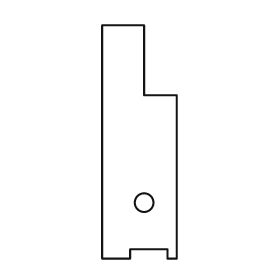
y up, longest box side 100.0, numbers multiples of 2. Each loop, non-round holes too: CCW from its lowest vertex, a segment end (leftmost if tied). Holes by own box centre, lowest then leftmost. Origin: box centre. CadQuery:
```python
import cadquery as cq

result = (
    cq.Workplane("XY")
    .moveTo(-16.0, -50.0)
    .lineTo(-4.0, -50.0)
    .lineTo(-4.0, -46.0)
    .lineTo(12.0, -46.0)
    .lineTo(12.0, -50.0)
    .lineTo(16.0, -50.0)
    .lineTo(16.0, 20.0)
    .lineTo(2.0, 20.0)
    .lineTo(2.0, 50.0)
    .lineTo(-16.0, 50.0)
    .close()
    .moveTo(2.0, -26.0)
    .circle(4.0)
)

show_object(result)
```